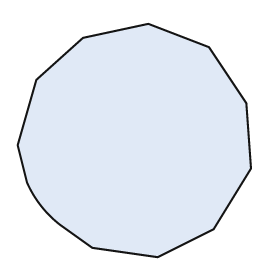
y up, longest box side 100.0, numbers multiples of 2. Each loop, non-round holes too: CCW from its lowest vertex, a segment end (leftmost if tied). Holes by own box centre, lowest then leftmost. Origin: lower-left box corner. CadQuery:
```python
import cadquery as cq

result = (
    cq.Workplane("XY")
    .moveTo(60.0, 0.0)
    .lineTo(84.0, 12.0)
    .lineTo(100.0, 38.0)
    .lineTo(98.0, 66.0)
    .lineTo(82.0, 90.0)
    .lineTo(56.0, 100.0)
    .lineTo(28.0, 94.0)
    .lineTo(8.0, 76.0)
    .lineTo(0.0, 48.0)
    .lineTo(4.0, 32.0)
    .threePointArc((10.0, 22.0), (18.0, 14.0))
    .lineTo(32.0, 4.0)
    .close()
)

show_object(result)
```